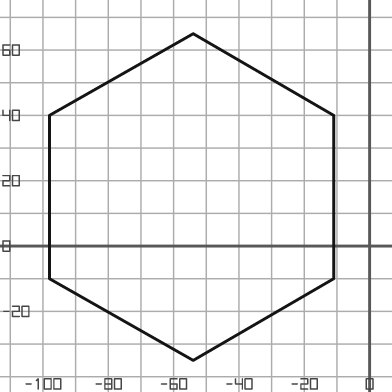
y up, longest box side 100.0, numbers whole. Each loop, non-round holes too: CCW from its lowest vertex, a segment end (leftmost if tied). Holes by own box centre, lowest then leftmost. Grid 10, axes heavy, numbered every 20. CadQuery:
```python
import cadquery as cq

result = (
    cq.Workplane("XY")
    .moveTo(-54.0, -35.0)
    .lineTo(-11.0, -10.0)
    .lineTo(-11.0, 40.0)
    .lineTo(-54.0, 65.0)
    .lineTo(-98.0, 40.0)
    .lineTo(-98.0, -10.0)
    .close()
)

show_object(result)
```